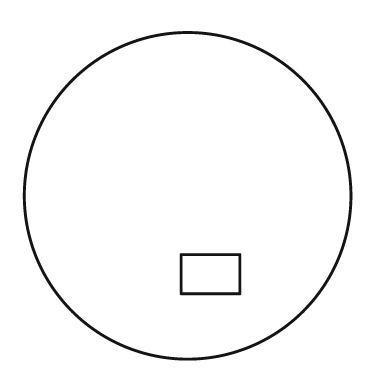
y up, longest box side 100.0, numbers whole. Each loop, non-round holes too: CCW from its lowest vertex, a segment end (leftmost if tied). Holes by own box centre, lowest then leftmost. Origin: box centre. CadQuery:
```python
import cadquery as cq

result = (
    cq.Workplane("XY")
    .moveTo(0.0, 0.0)
    .circle(50.0)
    .moveTo(-2.0, -30.0)
    .lineTo(16.0, -30.0)
    .lineTo(16.0, -18.0)
    .lineTo(-2.0, -18.0)
    .close()
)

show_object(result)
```